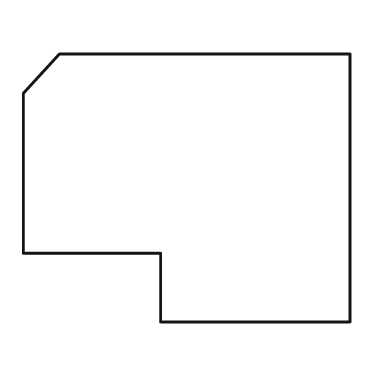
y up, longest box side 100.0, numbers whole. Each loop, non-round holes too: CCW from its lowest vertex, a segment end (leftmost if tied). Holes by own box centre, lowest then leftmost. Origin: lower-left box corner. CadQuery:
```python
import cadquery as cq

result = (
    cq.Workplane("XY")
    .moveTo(42.0, 0.0)
    .lineTo(100.0, 0.0)
    .lineTo(100.0, 82.0)
    .lineTo(11.0, 82.0)
    .lineTo(0.0, 70.0)
    .lineTo(0.0, 21.0)
    .lineTo(42.0, 21.0)
    .close()
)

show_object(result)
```